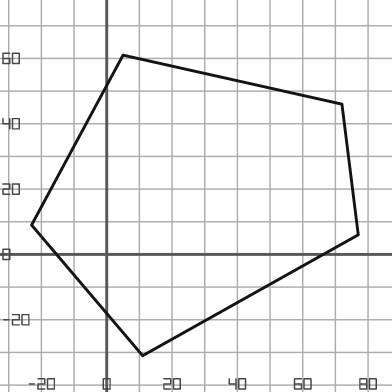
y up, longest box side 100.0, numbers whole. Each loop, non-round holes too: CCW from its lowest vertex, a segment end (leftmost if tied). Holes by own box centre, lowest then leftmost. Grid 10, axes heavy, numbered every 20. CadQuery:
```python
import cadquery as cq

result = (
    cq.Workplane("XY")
    .moveTo(11.0, -31.0)
    .lineTo(77.0, 6.0)
    .lineTo(72.0, 46.0)
    .lineTo(5.0, 61.0)
    .lineTo(-23.0, 9.0)
    .close()
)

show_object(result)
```